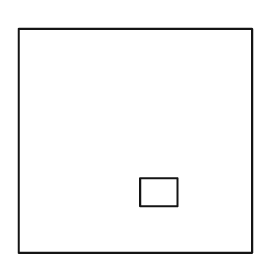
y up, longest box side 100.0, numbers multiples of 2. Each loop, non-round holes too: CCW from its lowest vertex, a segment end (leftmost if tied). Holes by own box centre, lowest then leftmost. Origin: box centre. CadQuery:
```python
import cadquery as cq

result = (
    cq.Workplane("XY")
    .moveTo(-50.0, -48.0)
    .lineTo(50.0, -48.0)
    .lineTo(50.0, 48.0)
    .lineTo(-50.0, 48.0)
    .close()
    .moveTo(2.0, -28.0)
    .lineTo(18.0, -28.0)
    .lineTo(18.0, -16.0)
    .lineTo(2.0, -16.0)
    .close()
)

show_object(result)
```